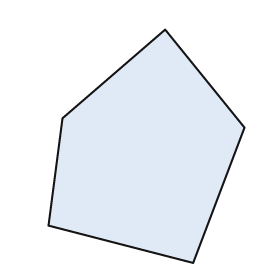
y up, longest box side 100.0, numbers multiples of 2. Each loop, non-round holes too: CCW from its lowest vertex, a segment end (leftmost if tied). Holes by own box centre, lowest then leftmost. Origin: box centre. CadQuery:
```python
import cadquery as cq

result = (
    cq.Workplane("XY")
    .moveTo(20.0, -50.0)
    .lineTo(42.0, 8.0)
    .lineTo(8.0, 50.0)
    .lineTo(-36.0, 12.0)
    .lineTo(-42.0, -34.0)
    .close()
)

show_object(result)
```